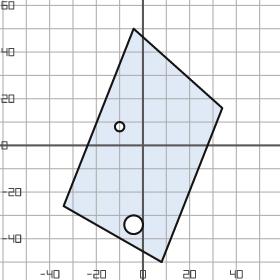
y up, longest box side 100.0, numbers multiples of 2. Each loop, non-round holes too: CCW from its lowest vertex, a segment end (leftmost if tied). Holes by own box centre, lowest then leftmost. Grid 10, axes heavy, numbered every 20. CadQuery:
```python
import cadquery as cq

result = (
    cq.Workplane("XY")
    .moveTo(8.0, -50.0)
    .lineTo(34.0, 16.0)
    .lineTo(-4.0, 50.0)
    .lineTo(-34.0, -26.0)
    .close()
    .moveTo(-4.0, -34.0)
    .circle(4.0)
    .moveTo(-10.0, 8.0)
    .circle(2.0)
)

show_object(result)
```